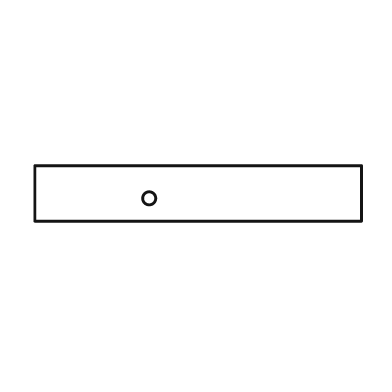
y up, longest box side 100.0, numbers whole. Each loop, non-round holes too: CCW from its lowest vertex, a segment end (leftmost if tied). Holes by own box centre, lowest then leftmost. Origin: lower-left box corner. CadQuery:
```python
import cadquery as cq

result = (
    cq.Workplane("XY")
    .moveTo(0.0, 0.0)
    .lineTo(100.0, 0.0)
    .lineTo(100.0, 17.0)
    .lineTo(0.0, 17.0)
    .close()
    .moveTo(35.0, 7.0)
    .circle(2.0)
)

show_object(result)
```